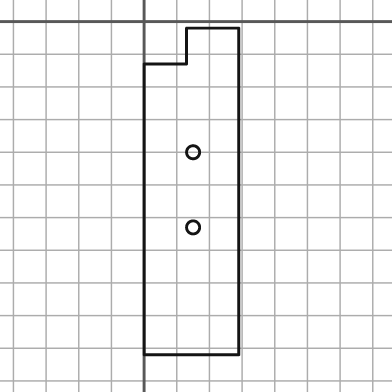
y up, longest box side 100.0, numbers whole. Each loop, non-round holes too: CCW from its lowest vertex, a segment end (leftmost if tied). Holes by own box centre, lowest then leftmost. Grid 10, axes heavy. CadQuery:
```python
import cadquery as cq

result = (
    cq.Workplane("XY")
    .moveTo(0.0, -102.0)
    .lineTo(29.0, -102.0)
    .lineTo(29.0, -2.0)
    .lineTo(13.0, -2.0)
    .lineTo(13.0, -13.0)
    .lineTo(0.0, -13.0)
    .close()
    .moveTo(15.0, -63.0)
    .circle(2.0)
    .moveTo(15.0, -40.0)
    .circle(2.0)
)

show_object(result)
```